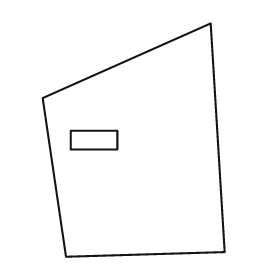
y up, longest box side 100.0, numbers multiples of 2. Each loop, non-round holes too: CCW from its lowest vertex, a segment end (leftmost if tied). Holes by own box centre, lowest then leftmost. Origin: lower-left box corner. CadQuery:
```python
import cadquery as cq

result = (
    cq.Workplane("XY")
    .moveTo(10.0, 0.0)
    .lineTo(78.0, 2.0)
    .lineTo(72.0, 100.0)
    .lineTo(0.0, 68.0)
    .close()
    .moveTo(12.0, 46.0)
    .lineTo(32.0, 46.0)
    .lineTo(32.0, 54.0)
    .lineTo(12.0, 54.0)
    .close()
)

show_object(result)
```